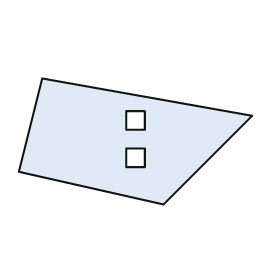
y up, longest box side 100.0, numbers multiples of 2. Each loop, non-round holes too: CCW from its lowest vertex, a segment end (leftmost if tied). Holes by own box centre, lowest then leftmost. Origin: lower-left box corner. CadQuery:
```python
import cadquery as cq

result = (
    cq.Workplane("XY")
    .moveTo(62.0, 0.0)
    .lineTo(100.0, 38.0)
    .lineTo(10.0, 54.0)
    .lineTo(0.0, 14.0)
    .close()
    .moveTo(46.0, 16.0)
    .lineTo(54.0, 16.0)
    .lineTo(54.0, 24.0)
    .lineTo(46.0, 24.0)
    .close()
    .moveTo(46.0, 32.0)
    .lineTo(54.0, 32.0)
    .lineTo(54.0, 40.0)
    .lineTo(46.0, 40.0)
    .close()
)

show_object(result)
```